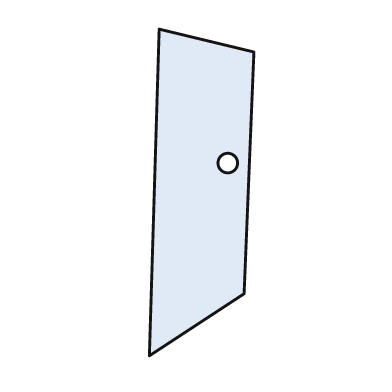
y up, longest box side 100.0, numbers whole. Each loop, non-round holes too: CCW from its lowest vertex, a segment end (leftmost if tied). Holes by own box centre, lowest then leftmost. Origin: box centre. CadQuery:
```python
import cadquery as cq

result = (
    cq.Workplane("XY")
    .moveTo(-16.0, -50.0)
    .lineTo(13.0, -31.0)
    .lineTo(16.0, 43.0)
    .lineTo(-13.0, 50.0)
    .close()
    .moveTo(8.0, 9.0)
    .circle(3.0)
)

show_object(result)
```